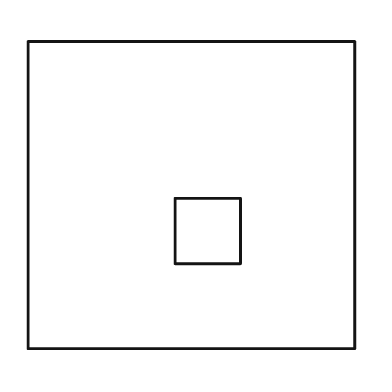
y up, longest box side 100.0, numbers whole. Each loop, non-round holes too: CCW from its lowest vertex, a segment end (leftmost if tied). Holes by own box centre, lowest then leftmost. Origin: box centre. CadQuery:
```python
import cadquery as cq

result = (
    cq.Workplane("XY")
    .moveTo(-50.0, -47.0)
    .lineTo(50.0, -47.0)
    .lineTo(50.0, 47.0)
    .lineTo(-50.0, 47.0)
    .close()
    .moveTo(-5.0, -21.0)
    .lineTo(15.0, -21.0)
    .lineTo(15.0, -1.0)
    .lineTo(-5.0, -1.0)
    .close()
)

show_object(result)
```